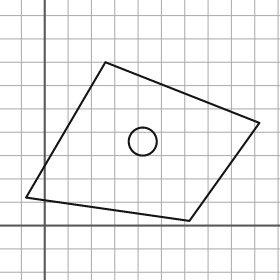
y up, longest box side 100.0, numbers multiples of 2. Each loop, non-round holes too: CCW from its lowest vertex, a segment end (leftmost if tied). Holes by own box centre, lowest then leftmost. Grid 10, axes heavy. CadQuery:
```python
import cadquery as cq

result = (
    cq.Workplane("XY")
    .moveTo(62.0, 2.0)
    .lineTo(92.0, 44.0)
    .lineTo(26.0, 70.0)
    .lineTo(-8.0, 12.0)
    .close()
    .moveTo(42.0, 36.0)
    .circle(6.0)
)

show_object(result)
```